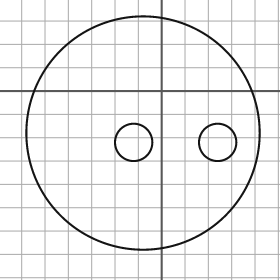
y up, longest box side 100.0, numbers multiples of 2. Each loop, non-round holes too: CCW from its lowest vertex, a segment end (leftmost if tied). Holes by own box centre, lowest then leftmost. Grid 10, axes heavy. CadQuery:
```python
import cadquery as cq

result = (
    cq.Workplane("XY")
    .moveTo(-8.0, -18.0)
    .circle(50.0)
    .moveTo(-12.0, -22.0)
    .circle(8.0)
    .moveTo(24.0, -22.0)
    .circle(8.0)
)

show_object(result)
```